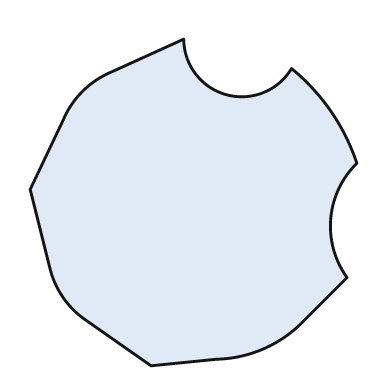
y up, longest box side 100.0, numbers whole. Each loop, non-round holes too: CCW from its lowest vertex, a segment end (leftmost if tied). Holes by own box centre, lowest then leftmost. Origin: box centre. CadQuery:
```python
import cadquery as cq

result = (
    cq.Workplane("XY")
    .moveTo(-13.0, -50.0)
    .lineTo(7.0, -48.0)
    .threePointArc((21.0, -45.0), (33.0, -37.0))
    .lineTo(47.0, -23.0)
    .threePointArc((42.0, -5.0), (50.0, 12.0))
    .threePointArc((42.0, 28.0), (30.0, 41.0))
    .threePointArc((10.0, 33.0), (-3.0, 50.0))
    .lineTo(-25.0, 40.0)
    .threePointArc((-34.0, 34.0), (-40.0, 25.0))
    .lineTo(-50.0, 4.0)
    .lineTo(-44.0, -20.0)
    .threePointArc((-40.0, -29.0), (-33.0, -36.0))
    .close()
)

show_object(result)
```